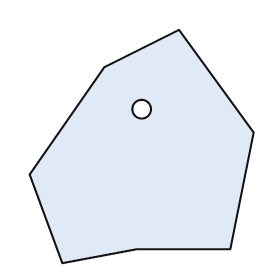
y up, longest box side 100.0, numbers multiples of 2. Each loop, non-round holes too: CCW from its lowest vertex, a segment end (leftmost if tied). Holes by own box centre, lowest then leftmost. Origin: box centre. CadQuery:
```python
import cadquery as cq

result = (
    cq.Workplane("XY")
    .moveTo(-34.0, -50.0)
    .lineTo(-2.0, -44.0)
    .lineTo(38.0, -44.0)
    .lineTo(48.0, 6.0)
    .lineTo(16.0, 50.0)
    .lineTo(-16.0, 34.0)
    .lineTo(-48.0, -12.0)
    .close()
    .moveTo(0.0, 16.0)
    .circle(4.0)
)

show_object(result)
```